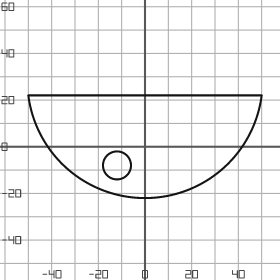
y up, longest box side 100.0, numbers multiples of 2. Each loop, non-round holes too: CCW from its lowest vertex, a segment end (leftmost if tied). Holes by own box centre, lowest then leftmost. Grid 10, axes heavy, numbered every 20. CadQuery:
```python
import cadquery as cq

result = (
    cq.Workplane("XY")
    .moveTo(-50.0, 22.0)
    .threePointArc((0.0, -22.0), (50.0, 22.0))
    .close()
    .moveTo(-12.0, -8.0)
    .circle(6.0)
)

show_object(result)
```